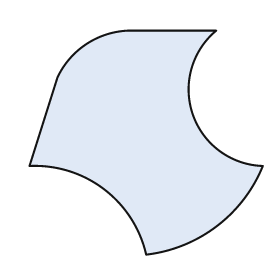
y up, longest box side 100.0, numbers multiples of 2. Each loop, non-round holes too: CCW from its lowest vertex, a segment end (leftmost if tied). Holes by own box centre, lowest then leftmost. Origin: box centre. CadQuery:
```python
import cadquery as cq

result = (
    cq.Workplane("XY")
    .moveTo(0.0, -48.0)
    .threePointArc((30.0, -36.0), (50.0, -10.0))
    .threePointArc((20.0, 12.0), (30.0, 48.0))
    .lineTo(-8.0, 48.0)
    .threePointArc((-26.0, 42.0), (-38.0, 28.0))
    .lineTo(-50.0, -10.0)
    .threePointArc((-18.0, -20.0), (0.0, -48.0))
    .close()
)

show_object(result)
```